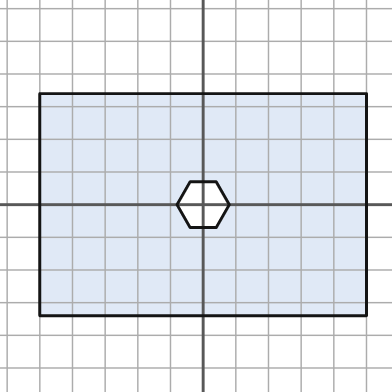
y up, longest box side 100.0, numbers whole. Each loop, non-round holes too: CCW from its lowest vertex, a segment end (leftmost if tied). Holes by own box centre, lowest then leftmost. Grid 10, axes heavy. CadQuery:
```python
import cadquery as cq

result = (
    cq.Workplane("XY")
    .moveTo(-50.0, -34.0)
    .lineTo(50.0, -34.0)
    .lineTo(50.0, 34.0)
    .lineTo(-50.0, 34.0)
    .close()
    .moveTo(-4.0, -7.0)
    .lineTo(4.0, -7.0)
    .lineTo(8.0, 0.0)
    .lineTo(4.0, 7.0)
    .lineTo(-4.0, 7.0)
    .lineTo(-8.0, 0.0)
    .close()
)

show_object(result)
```